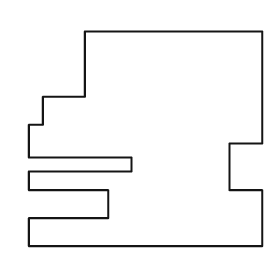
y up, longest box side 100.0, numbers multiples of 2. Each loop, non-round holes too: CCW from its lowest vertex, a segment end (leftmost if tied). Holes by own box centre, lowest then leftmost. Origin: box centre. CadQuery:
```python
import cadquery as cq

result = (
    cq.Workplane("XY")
    .moveTo(-50.0, -46.0)
    .lineTo(50.0, -46.0)
    .lineTo(50.0, -22.0)
    .lineTo(36.0, -22.0)
    .lineTo(36.0, -2.0)
    .lineTo(50.0, -2.0)
    .lineTo(50.0, 46.0)
    .lineTo(-26.0, 46.0)
    .lineTo(-26.0, 18.0)
    .lineTo(-44.0, 18.0)
    .lineTo(-44.0, 6.0)
    .lineTo(-50.0, 6.0)
    .lineTo(-50.0, -8.0)
    .lineTo(-6.0, -8.0)
    .lineTo(-6.0, -14.0)
    .lineTo(-50.0, -14.0)
    .lineTo(-50.0, -22.0)
    .lineTo(-16.0, -22.0)
    .lineTo(-16.0, -34.0)
    .lineTo(-50.0, -34.0)
    .close()
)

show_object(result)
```